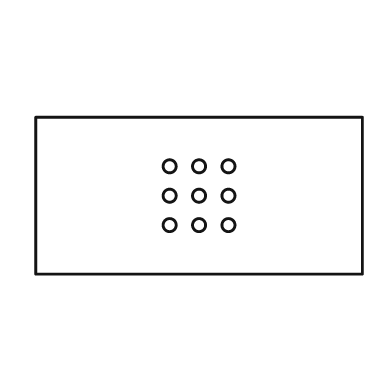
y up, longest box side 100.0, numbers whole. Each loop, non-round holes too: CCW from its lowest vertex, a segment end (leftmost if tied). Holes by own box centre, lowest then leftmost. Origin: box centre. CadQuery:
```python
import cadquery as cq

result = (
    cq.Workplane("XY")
    .moveTo(-50.0, -24.0)
    .lineTo(50.0, -24.0)
    .lineTo(50.0, 24.0)
    .lineTo(-50.0, 24.0)
    .close()
    .moveTo(-9.0, -9.0)
    .circle(2.0)
    .moveTo(0.0, -9.0)
    .circle(2.0)
    .moveTo(9.0, -9.0)
    .circle(2.0)
    .moveTo(-9.0, 0.0)
    .circle(2.0)
    .moveTo(0.0, 0.0)
    .circle(2.0)
    .moveTo(9.0, 0.0)
    .circle(2.0)
    .moveTo(-9.0, 9.0)
    .circle(2.0)
    .moveTo(0.0, 9.0)
    .circle(2.0)
    .moveTo(9.0, 9.0)
    .circle(2.0)
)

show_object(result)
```